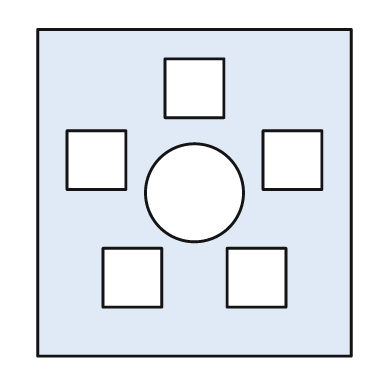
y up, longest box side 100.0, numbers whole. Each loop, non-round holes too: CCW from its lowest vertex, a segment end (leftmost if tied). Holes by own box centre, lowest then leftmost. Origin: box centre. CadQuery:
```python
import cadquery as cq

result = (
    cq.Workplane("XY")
    .moveTo(-48.0, -50.0)
    .lineTo(48.0, -50.0)
    .lineTo(48.0, 50.0)
    .lineTo(-48.0, 50.0)
    .close()
    .moveTo(-28.0, -35.0)
    .lineTo(-10.0, -35.0)
    .lineTo(-10.0, -17.0)
    .lineTo(-28.0, -17.0)
    .close()
    .moveTo(10.0, -35.0)
    .lineTo(28.0, -35.0)
    .lineTo(28.0, -17.0)
    .lineTo(10.0, -17.0)
    .close()
    .moveTo(0.0, 0.0)
    .circle(15.0)
    .moveTo(-39.0, 1.0)
    .lineTo(-21.0, 1.0)
    .lineTo(-21.0, 19.0)
    .lineTo(-39.0, 19.0)
    .close()
    .moveTo(21.0, 1.0)
    .lineTo(39.0, 1.0)
    .lineTo(39.0, 19.0)
    .lineTo(21.0, 19.0)
    .close()
    .moveTo(-9.0, 23.0)
    .lineTo(9.0, 23.0)
    .lineTo(9.0, 41.0)
    .lineTo(-9.0, 41.0)
    .close()
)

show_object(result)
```